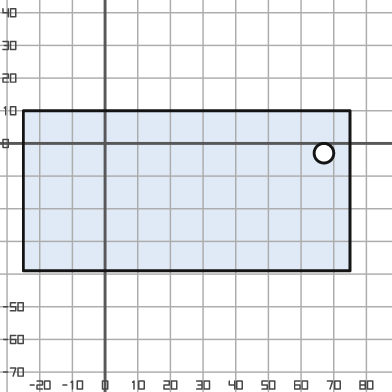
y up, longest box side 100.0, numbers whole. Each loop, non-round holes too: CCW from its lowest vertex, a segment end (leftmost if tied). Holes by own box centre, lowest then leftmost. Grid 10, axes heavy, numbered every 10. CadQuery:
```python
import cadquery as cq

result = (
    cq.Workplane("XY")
    .moveTo(-25.0, -39.0)
    .lineTo(75.0, -39.0)
    .lineTo(75.0, 10.0)
    .lineTo(-25.0, 10.0)
    .close()
    .moveTo(67.0, -3.0)
    .circle(3.0)
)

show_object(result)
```